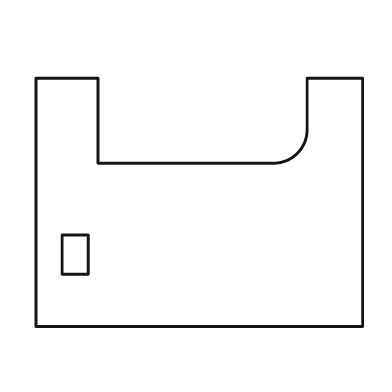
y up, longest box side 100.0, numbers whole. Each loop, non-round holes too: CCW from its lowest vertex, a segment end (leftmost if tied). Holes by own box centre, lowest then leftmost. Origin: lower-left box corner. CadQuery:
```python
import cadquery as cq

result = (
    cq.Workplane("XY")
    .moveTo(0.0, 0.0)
    .lineTo(100.0, 0.0)
    .lineTo(100.0, 76.0)
    .lineTo(83.0, 76.0)
    .lineTo(83.0, 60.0)
    .threePointArc((80.0, 53.0), (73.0, 50.0))
    .lineTo(19.0, 50.0)
    .lineTo(19.0, 76.0)
    .lineTo(0.0, 76.0)
    .close()
    .moveTo(8.0, 16.0)
    .lineTo(16.0, 16.0)
    .lineTo(16.0, 28.0)
    .lineTo(8.0, 28.0)
    .close()
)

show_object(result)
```